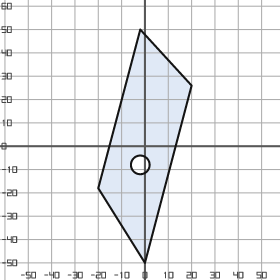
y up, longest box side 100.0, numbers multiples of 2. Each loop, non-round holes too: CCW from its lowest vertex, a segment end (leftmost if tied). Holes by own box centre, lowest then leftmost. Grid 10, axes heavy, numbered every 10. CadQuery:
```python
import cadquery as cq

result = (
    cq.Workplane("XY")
    .moveTo(0.0, -50.0)
    .lineTo(20.0, 26.0)
    .lineTo(-2.0, 50.0)
    .lineTo(-20.0, -18.0)
    .close()
    .moveTo(-2.0, -8.0)
    .circle(4.0)
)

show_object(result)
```